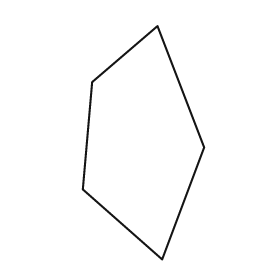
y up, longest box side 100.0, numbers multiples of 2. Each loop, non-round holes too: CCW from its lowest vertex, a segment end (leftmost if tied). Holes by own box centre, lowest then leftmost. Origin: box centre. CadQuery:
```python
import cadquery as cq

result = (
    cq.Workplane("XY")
    .moveTo(8.0, -50.0)
    .lineTo(26.0, -2.0)
    .lineTo(6.0, 50.0)
    .lineTo(-22.0, 26.0)
    .lineTo(-26.0, -20.0)
    .close()
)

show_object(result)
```